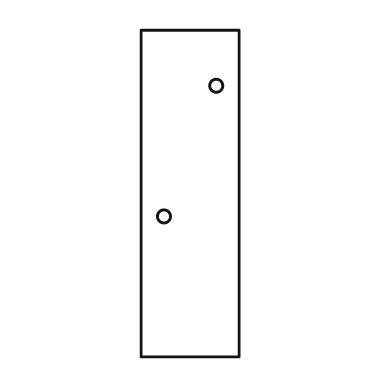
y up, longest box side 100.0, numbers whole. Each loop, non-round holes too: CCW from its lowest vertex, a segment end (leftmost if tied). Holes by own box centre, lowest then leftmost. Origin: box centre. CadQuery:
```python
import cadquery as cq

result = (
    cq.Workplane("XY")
    .moveTo(-15.0, -50.0)
    .lineTo(15.0, -50.0)
    .lineTo(15.0, 50.0)
    .lineTo(-15.0, 50.0)
    .close()
    .moveTo(-8.0, -7.0)
    .circle(2.0)
    .moveTo(8.0, 33.0)
    .circle(2.0)
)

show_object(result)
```